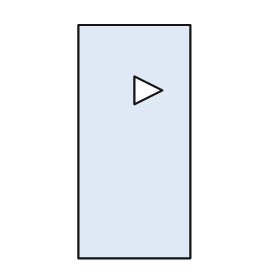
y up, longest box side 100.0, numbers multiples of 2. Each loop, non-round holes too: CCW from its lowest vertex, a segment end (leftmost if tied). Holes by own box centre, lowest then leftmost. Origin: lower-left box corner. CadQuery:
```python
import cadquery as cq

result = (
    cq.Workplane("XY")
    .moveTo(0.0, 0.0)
    .lineTo(48.0, 0.0)
    .lineTo(48.0, 100.0)
    .lineTo(0.0, 100.0)
    .close()
    .moveTo(24.0, 66.0)
    .lineTo(36.0, 72.0)
    .lineTo(24.0, 78.0)
    .close()
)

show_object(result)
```